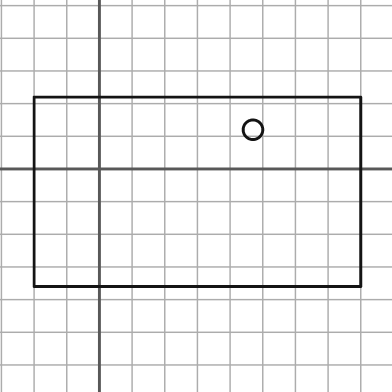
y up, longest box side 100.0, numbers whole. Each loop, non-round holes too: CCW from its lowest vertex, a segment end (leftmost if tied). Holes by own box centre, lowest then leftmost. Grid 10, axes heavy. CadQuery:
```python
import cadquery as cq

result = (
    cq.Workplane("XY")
    .moveTo(-20.0, -36.0)
    .lineTo(80.0, -36.0)
    .lineTo(80.0, 22.0)
    .lineTo(-20.0, 22.0)
    .close()
    .moveTo(47.0, 12.0)
    .circle(3.0)
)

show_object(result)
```